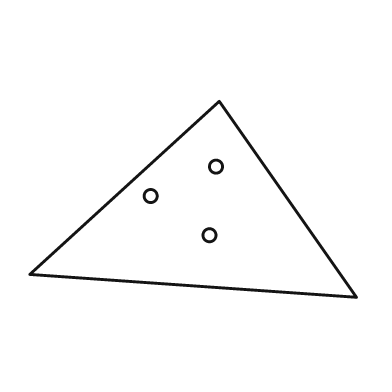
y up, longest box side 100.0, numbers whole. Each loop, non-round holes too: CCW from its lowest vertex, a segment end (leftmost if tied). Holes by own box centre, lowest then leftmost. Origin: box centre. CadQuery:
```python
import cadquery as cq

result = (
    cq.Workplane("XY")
    .moveTo(50.0, -30.0)
    .lineTo(8.0, 30.0)
    .lineTo(-50.0, -23.0)
    .close()
    .moveTo(5.0, -11.0)
    .circle(2.0)
    .moveTo(-13.0, 1.0)
    .circle(2.0)
    .moveTo(7.0, 10.0)
    .circle(2.0)
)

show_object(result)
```